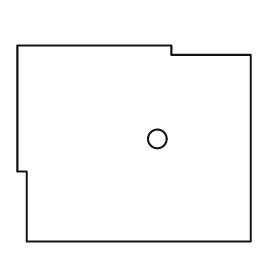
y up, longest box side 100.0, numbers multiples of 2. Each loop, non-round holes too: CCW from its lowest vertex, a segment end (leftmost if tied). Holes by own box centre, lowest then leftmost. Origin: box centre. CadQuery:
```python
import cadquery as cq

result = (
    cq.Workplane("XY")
    .moveTo(-46.0, -42.0)
    .lineTo(50.0, -42.0)
    .lineTo(50.0, 38.0)
    .lineTo(16.0, 38.0)
    .lineTo(16.0, 42.0)
    .lineTo(-50.0, 42.0)
    .lineTo(-50.0, -12.0)
    .lineTo(-46.0, -12.0)
    .close()
    .moveTo(10.0, 2.0)
    .circle(4.0)
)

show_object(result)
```